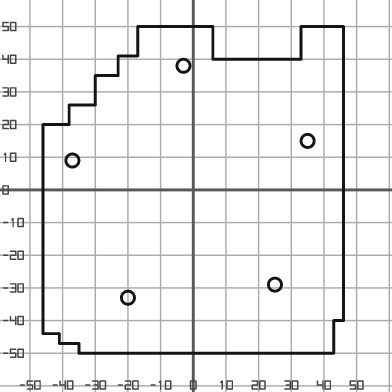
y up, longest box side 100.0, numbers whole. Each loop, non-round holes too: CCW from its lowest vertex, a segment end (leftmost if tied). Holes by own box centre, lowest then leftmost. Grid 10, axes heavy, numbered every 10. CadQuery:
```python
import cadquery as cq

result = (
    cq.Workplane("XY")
    .moveTo(-35.0, -50.0)
    .lineTo(43.0, -50.0)
    .lineTo(43.0, -40.0)
    .lineTo(46.0, -40.0)
    .lineTo(46.0, 50.0)
    .lineTo(33.0, 50.0)
    .lineTo(33.0, 40.0)
    .lineTo(6.0, 40.0)
    .lineTo(6.0, 50.0)
    .lineTo(-17.0, 50.0)
    .lineTo(-17.0, 41.0)
    .lineTo(-23.0, 41.0)
    .lineTo(-23.0, 35.0)
    .lineTo(-30.0, 35.0)
    .lineTo(-30.0, 26.0)
    .lineTo(-38.0, 26.0)
    .lineTo(-38.0, 20.0)
    .lineTo(-46.0, 20.0)
    .lineTo(-46.0, -44.0)
    .lineTo(-41.0, -44.0)
    .lineTo(-41.0, -47.0)
    .lineTo(-35.0, -47.0)
    .close()
    .moveTo(-20.0, -33.0)
    .circle(2.0)
    .moveTo(25.0, -29.0)
    .circle(2.0)
    .moveTo(-37.0, 9.0)
    .circle(2.0)
    .moveTo(35.0, 15.0)
    .circle(2.0)
    .moveTo(-3.0, 38.0)
    .circle(2.0)
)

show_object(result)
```